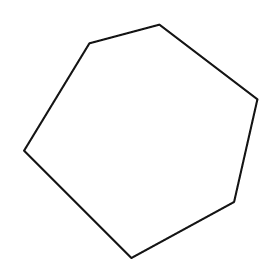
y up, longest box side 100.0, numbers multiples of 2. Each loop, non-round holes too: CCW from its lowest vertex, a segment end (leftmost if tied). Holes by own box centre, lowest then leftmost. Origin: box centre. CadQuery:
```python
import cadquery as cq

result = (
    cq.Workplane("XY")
    .moveTo(-4.0, -50.0)
    .lineTo(40.0, -26.0)
    .lineTo(50.0, 18.0)
    .lineTo(8.0, 50.0)
    .lineTo(-22.0, 42.0)
    .lineTo(-50.0, -4.0)
    .close()
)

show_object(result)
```